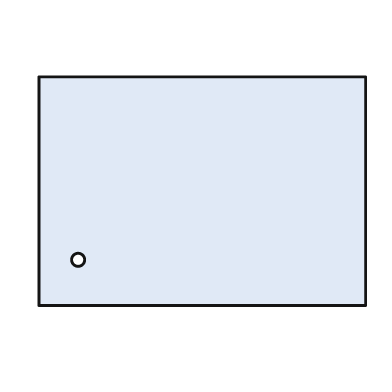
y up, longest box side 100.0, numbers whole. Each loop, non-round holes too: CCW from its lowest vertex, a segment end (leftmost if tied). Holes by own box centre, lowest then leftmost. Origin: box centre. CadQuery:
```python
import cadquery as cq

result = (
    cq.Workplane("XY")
    .moveTo(-50.0, -35.0)
    .lineTo(50.0, -35.0)
    .lineTo(50.0, 35.0)
    .lineTo(-50.0, 35.0)
    .close()
    .moveTo(-38.0, -21.0)
    .circle(2.0)
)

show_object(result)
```